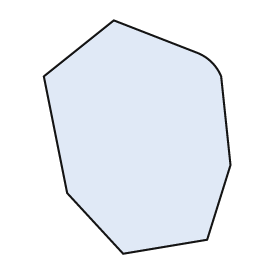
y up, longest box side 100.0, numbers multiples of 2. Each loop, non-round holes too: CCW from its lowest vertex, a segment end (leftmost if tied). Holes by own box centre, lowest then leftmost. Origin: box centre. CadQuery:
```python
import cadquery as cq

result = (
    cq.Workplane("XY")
    .moveTo(-6.0, -50.0)
    .lineTo(30.0, -44.0)
    .lineTo(40.0, -12.0)
    .lineTo(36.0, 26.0)
    .threePointArc((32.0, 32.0), (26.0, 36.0))
    .lineTo(-10.0, 50.0)
    .lineTo(-40.0, 26.0)
    .lineTo(-30.0, -24.0)
    .close()
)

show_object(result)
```